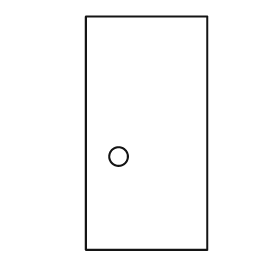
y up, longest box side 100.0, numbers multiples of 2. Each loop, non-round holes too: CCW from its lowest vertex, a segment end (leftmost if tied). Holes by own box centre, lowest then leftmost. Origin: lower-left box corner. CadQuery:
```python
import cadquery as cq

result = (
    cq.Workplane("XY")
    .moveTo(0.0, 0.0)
    .lineTo(52.0, 0.0)
    .lineTo(52.0, 100.0)
    .lineTo(0.0, 100.0)
    .close()
    .moveTo(14.0, 40.0)
    .circle(4.0)
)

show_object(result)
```